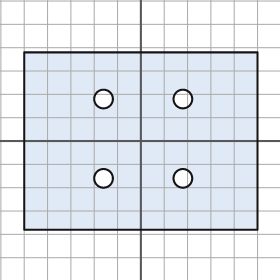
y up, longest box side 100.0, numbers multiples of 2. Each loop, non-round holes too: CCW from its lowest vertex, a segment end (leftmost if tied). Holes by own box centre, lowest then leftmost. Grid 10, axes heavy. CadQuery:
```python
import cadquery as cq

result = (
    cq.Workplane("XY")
    .moveTo(-50.0, -38.0)
    .lineTo(50.0, -38.0)
    .lineTo(50.0, 38.0)
    .lineTo(-50.0, 38.0)
    .close()
    .moveTo(-16.0, -16.0)
    .circle(4.0)
    .moveTo(18.0, -16.0)
    .circle(4.0)
    .moveTo(-16.0, 18.0)
    .circle(4.0)
    .moveTo(18.0, 18.0)
    .circle(4.0)
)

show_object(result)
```